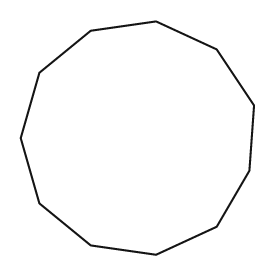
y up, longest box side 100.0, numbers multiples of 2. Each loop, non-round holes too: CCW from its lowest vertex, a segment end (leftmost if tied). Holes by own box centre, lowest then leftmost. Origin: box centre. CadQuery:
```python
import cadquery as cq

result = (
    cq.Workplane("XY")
    .moveTo(8.0, -50.0)
    .lineTo(34.0, -38.0)
    .lineTo(48.0, -14.0)
    .lineTo(50.0, 14.0)
    .lineTo(34.0, 38.0)
    .lineTo(8.0, 50.0)
    .lineTo(-20.0, 46.0)
    .lineTo(-42.0, 28.0)
    .lineTo(-50.0, 0.0)
    .lineTo(-42.0, -28.0)
    .lineTo(-20.0, -46.0)
    .close()
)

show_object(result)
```